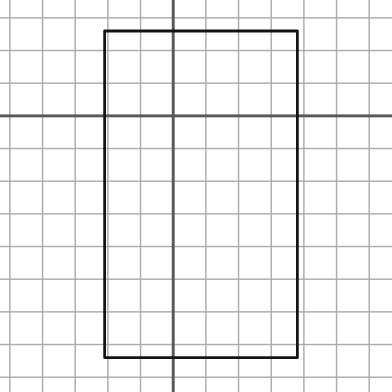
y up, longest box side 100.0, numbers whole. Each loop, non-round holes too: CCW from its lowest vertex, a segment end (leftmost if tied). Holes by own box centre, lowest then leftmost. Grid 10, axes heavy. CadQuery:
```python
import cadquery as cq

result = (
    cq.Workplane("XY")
    .moveTo(-21.0, -74.0)
    .lineTo(38.0, -74.0)
    .lineTo(38.0, 26.0)
    .lineTo(-21.0, 26.0)
    .close()
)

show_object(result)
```